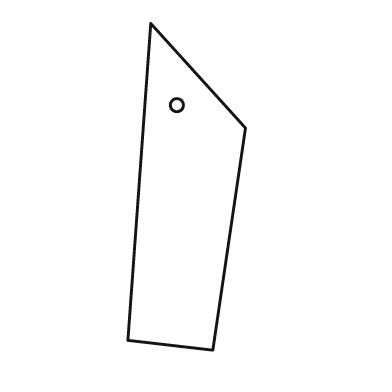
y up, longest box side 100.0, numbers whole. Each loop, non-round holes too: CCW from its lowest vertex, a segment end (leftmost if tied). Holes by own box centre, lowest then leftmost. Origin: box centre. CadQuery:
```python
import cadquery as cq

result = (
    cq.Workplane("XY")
    .moveTo(8.0, -50.0)
    .lineTo(18.0, 18.0)
    .lineTo(-11.0, 50.0)
    .lineTo(-18.0, -47.0)
    .close()
    .moveTo(-3.0, 25.0)
    .circle(2.0)
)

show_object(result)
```